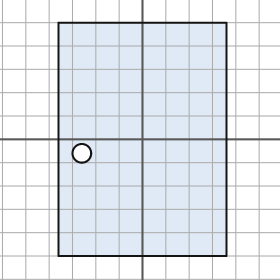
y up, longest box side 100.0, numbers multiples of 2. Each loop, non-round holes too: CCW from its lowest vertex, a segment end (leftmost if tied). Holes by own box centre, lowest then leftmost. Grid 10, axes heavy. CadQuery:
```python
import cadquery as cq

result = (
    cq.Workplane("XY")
    .moveTo(-36.0, -50.0)
    .lineTo(36.0, -50.0)
    .lineTo(36.0, 50.0)
    .lineTo(-36.0, 50.0)
    .close()
    .moveTo(-26.0, -6.0)
    .circle(4.0)
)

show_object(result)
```